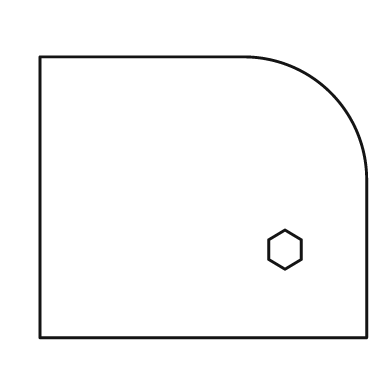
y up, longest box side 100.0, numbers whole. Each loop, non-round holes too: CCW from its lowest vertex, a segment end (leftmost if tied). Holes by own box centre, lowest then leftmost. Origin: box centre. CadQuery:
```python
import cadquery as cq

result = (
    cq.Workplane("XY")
    .moveTo(-50.0, -43.0)
    .lineTo(50.0, -43.0)
    .lineTo(50.0, 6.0)
    .threePointArc((39.0, 32.0), (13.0, 43.0))
    .lineTo(-50.0, 43.0)
    .close()
    .moveTo(25.0, -22.0)
    .lineTo(30.0, -19.0)
    .lineTo(30.0, -13.0)
    .lineTo(25.0, -10.0)
    .lineTo(20.0, -13.0)
    .lineTo(20.0, -19.0)
    .close()
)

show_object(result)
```